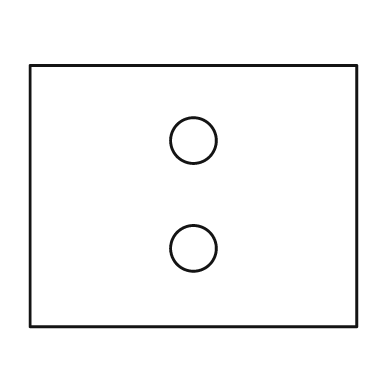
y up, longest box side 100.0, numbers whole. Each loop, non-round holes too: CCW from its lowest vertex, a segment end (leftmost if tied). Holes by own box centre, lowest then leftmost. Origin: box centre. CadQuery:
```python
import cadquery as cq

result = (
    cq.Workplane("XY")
    .moveTo(-50.0, -40.0)
    .lineTo(50.0, -40.0)
    .lineTo(50.0, 40.0)
    .lineTo(-50.0, 40.0)
    .close()
    .moveTo(0.0, -16.0)
    .circle(7.0)
    .moveTo(0.0, 17.0)
    .circle(7.0)
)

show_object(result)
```